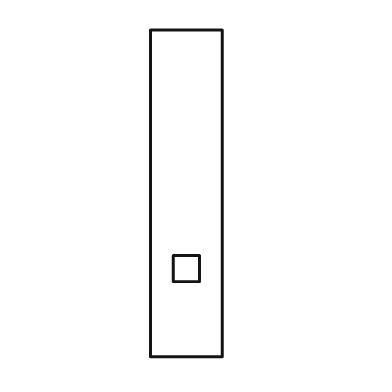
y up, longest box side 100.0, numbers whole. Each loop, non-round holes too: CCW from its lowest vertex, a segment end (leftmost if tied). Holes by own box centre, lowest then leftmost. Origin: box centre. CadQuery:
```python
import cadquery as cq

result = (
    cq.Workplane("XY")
    .moveTo(-11.0, -50.0)
    .lineTo(11.0, -50.0)
    .lineTo(11.0, 50.0)
    .lineTo(-11.0, 50.0)
    .close()
    .moveTo(-4.0, -27.0)
    .lineTo(4.0, -27.0)
    .lineTo(4.0, -19.0)
    .lineTo(-4.0, -19.0)
    .close()
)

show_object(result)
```